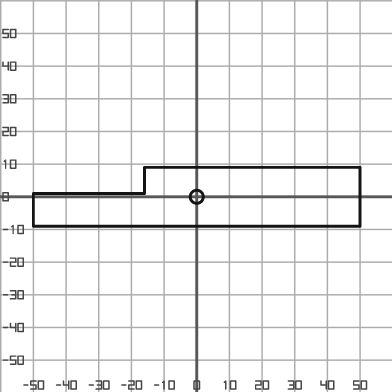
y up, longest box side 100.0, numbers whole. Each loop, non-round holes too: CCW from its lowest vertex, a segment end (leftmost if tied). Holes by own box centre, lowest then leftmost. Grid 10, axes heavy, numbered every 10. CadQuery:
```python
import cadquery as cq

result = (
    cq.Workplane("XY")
    .moveTo(-50.0, -9.0)
    .lineTo(50.0, -9.0)
    .lineTo(50.0, 9.0)
    .lineTo(-16.0, 9.0)
    .lineTo(-16.0, 1.0)
    .lineTo(-50.0, 1.0)
    .close()
    .moveTo(0.0, 0.0)
    .circle(2.0)
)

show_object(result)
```